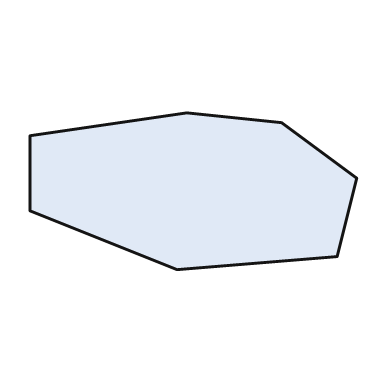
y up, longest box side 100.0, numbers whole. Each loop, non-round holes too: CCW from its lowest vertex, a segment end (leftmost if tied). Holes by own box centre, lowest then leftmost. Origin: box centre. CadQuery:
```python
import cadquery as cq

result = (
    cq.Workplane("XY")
    .moveTo(-5.0, -24.0)
    .lineTo(44.0, -20.0)
    .lineTo(50.0, 4.0)
    .lineTo(27.0, 21.0)
    .lineTo(-2.0, 24.0)
    .lineTo(-50.0, 17.0)
    .lineTo(-50.0, -6.0)
    .close()
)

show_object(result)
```